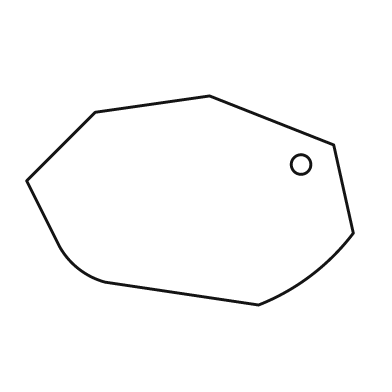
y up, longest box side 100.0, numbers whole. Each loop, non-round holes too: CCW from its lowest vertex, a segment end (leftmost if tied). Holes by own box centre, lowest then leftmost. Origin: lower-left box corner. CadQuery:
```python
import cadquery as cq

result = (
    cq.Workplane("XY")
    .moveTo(71.0, 0.0)
    .threePointArc((87.0, 9.0), (100.0, 22.0))
    .lineTo(94.0, 49.0)
    .lineTo(56.0, 64.0)
    .lineTo(21.0, 59.0)
    .lineTo(0.0, 38.0)
    .lineTo(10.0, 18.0)
    .threePointArc((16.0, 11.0), (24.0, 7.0))
    .close()
    .moveTo(84.0, 43.0)
    .circle(3.0)
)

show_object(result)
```